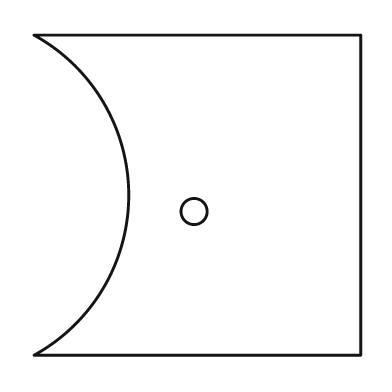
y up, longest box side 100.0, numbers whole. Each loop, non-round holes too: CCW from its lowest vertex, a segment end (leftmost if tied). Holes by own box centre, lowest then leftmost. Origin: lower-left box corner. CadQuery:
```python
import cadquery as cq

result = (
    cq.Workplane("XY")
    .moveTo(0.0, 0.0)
    .lineTo(100.0, 0.0)
    .lineTo(100.0, 98.0)
    .lineTo(0.0, 98.0)
    .threePointArc((29.0, 49.0), (0.0, 0.0))
    .close()
    .moveTo(49.0, 44.0)
    .circle(4.0)
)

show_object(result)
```